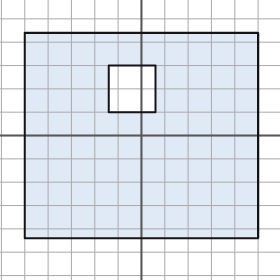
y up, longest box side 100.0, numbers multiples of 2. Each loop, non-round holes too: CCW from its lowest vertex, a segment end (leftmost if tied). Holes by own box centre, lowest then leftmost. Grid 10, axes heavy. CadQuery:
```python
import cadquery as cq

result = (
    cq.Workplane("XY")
    .moveTo(-50.0, -44.0)
    .lineTo(50.0, -44.0)
    .lineTo(50.0, 44.0)
    .lineTo(-50.0, 44.0)
    .close()
    .moveTo(-14.0, 10.0)
    .lineTo(6.0, 10.0)
    .lineTo(6.0, 30.0)
    .lineTo(-14.0, 30.0)
    .close()
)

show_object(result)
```